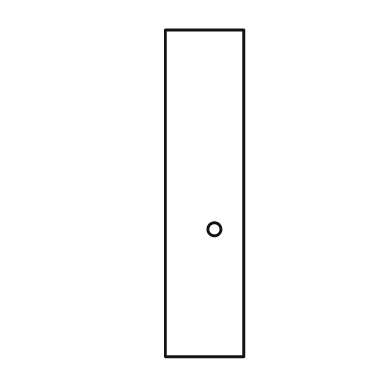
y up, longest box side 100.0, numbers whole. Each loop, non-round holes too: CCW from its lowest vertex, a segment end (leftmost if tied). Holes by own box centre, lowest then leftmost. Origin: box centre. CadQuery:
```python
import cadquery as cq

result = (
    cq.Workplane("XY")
    .moveTo(-12.0, -50.0)
    .lineTo(12.0, -50.0)
    .lineTo(12.0, 50.0)
    .lineTo(-12.0, 50.0)
    .close()
    .moveTo(3.0, -11.0)
    .circle(2.0)
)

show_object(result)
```